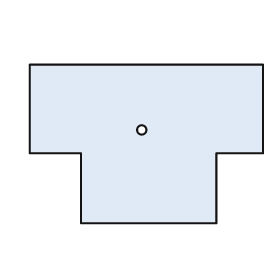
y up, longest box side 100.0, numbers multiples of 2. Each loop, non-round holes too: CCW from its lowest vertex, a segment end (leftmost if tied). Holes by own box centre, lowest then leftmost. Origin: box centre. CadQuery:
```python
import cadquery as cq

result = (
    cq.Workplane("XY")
    .moveTo(-28.0, -34.0)
    .lineTo(30.0, -34.0)
    .lineTo(30.0, -4.0)
    .lineTo(50.0, -4.0)
    .lineTo(50.0, 34.0)
    .lineTo(-50.0, 34.0)
    .lineTo(-50.0, -4.0)
    .lineTo(-28.0, -4.0)
    .close()
    .moveTo(-2.0, 6.0)
    .circle(2.0)
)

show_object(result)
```